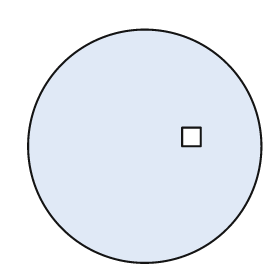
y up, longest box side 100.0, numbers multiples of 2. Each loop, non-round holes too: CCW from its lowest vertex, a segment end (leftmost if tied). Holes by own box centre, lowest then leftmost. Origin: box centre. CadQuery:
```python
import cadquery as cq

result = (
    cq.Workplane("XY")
    .moveTo(0.0, 0.0)
    .circle(50.0)
    .moveTo(16.0, 0.0)
    .lineTo(24.0, 0.0)
    .lineTo(24.0, 8.0)
    .lineTo(16.0, 8.0)
    .close()
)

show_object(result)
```